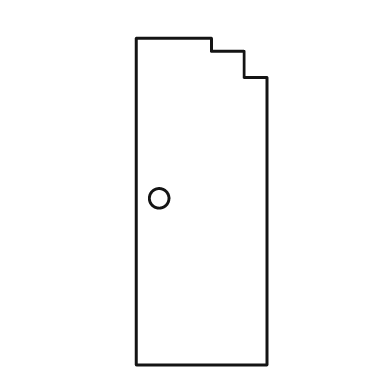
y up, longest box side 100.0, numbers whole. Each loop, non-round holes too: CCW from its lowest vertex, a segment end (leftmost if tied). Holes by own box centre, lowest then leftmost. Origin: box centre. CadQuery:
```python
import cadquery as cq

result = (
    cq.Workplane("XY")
    .moveTo(-20.0, -50.0)
    .lineTo(20.0, -50.0)
    .lineTo(20.0, 38.0)
    .lineTo(13.0, 38.0)
    .lineTo(13.0, 46.0)
    .lineTo(3.0, 46.0)
    .lineTo(3.0, 50.0)
    .lineTo(-20.0, 50.0)
    .close()
    .moveTo(-13.0, 1.0)
    .circle(3.0)
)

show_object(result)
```